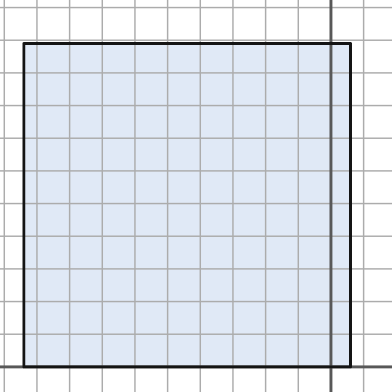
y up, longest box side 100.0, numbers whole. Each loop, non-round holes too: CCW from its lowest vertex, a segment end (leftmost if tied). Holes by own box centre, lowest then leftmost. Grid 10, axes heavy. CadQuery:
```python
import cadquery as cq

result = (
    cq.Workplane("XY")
    .moveTo(-94.0, 0.0)
    .lineTo(6.0, 0.0)
    .lineTo(6.0, 99.0)
    .lineTo(-94.0, 99.0)
    .close()
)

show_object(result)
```